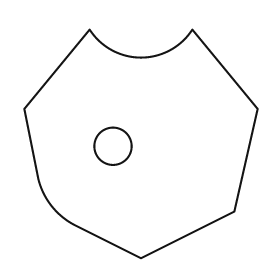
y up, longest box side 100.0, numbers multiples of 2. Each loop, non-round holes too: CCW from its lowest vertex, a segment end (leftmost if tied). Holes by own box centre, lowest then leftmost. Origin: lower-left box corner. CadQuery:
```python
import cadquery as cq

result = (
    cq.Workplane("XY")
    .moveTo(50.0, 0.0)
    .lineTo(90.0, 20.0)
    .lineTo(100.0, 64.0)
    .lineTo(72.0, 98.0)
    .threePointArc((50.0, 86.0), (28.0, 98.0))
    .lineTo(0.0, 64.0)
    .lineTo(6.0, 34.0)
    .threePointArc((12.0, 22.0), (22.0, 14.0))
    .close()
    .moveTo(38.0, 48.0)
    .circle(8.0)
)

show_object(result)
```